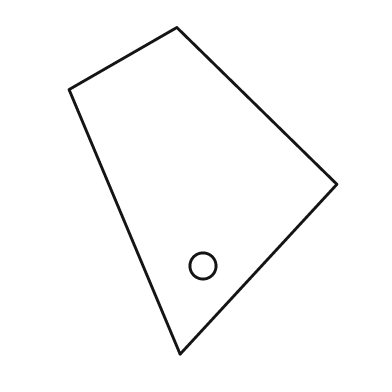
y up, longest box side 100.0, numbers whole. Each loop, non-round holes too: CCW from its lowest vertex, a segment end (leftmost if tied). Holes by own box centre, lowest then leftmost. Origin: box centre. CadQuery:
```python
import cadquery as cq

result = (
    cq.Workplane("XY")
    .moveTo(-7.0, -50.0)
    .lineTo(41.0, 2.0)
    .lineTo(-8.0, 50.0)
    .lineTo(-41.0, 31.0)
    .close()
    .moveTo(0.0, -23.0)
    .circle(4.0)
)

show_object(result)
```